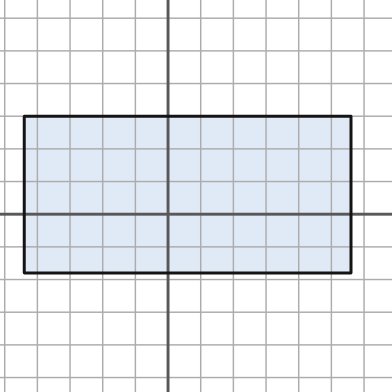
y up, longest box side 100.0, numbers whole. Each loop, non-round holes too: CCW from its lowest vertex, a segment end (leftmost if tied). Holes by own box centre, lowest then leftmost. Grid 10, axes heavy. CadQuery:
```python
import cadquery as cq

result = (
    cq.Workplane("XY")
    .moveTo(-44.0, -18.0)
    .lineTo(56.0, -18.0)
    .lineTo(56.0, 30.0)
    .lineTo(-44.0, 30.0)
    .close()
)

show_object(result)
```